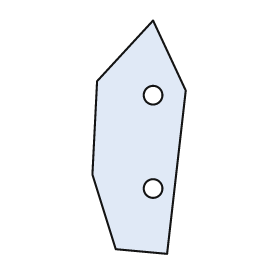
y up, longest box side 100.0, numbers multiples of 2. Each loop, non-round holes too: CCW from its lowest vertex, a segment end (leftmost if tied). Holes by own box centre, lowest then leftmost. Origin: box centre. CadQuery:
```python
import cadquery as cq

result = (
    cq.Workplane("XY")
    .moveTo(12.0, -50.0)
    .lineTo(20.0, 20.0)
    .lineTo(6.0, 50.0)
    .lineTo(-18.0, 24.0)
    .lineTo(-20.0, -16.0)
    .lineTo(-10.0, -48.0)
    .close()
    .moveTo(6.0, -22.0)
    .circle(4.0)
    .moveTo(6.0, 18.0)
    .circle(4.0)
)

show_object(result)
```